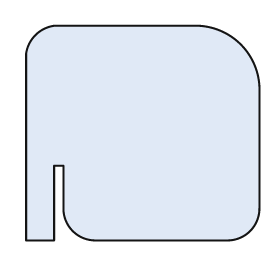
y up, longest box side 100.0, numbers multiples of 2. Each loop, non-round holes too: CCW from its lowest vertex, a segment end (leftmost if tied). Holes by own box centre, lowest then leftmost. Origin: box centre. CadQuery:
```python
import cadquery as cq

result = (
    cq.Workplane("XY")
    .moveTo(-50.0, -46.0)
    .lineTo(-38.0, -46.0)
    .lineTo(-38.0, -14.0)
    .lineTo(-34.0, -14.0)
    .lineTo(-34.0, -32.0)
    .threePointArc((-30.0, -42.0), (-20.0, -46.0))
    .lineTo(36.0, -46.0)
    .threePointArc((46.0, -42.0), (50.0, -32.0))
    .lineTo(50.0, 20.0)
    .threePointArc((42.0, 38.0), (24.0, 46.0))
    .lineTo(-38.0, 46.0)
    .threePointArc((-46.0, 42.0), (-50.0, 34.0))
    .close()
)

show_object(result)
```